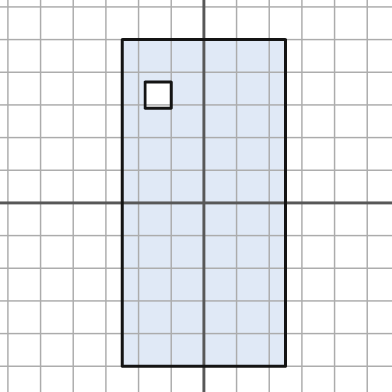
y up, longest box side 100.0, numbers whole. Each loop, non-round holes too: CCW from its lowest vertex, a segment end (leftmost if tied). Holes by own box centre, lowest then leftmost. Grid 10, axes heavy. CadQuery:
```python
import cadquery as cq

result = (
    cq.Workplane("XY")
    .moveTo(-25.0, -50.0)
    .lineTo(25.0, -50.0)
    .lineTo(25.0, 50.0)
    .lineTo(-25.0, 50.0)
    .close()
    .moveTo(-18.0, 29.0)
    .lineTo(-10.0, 29.0)
    .lineTo(-10.0, 37.0)
    .lineTo(-18.0, 37.0)
    .close()
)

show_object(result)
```